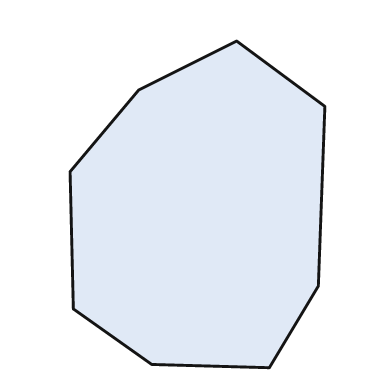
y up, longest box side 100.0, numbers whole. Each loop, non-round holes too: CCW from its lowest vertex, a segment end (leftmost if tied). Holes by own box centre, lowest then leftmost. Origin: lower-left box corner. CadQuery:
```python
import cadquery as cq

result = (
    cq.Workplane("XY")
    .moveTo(61.0, 0.0)
    .lineTo(76.0, 25.0)
    .lineTo(78.0, 80.0)
    .lineTo(51.0, 100.0)
    .lineTo(21.0, 85.0)
    .lineTo(0.0, 60.0)
    .lineTo(1.0, 18.0)
    .lineTo(25.0, 1.0)
    .close()
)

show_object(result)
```